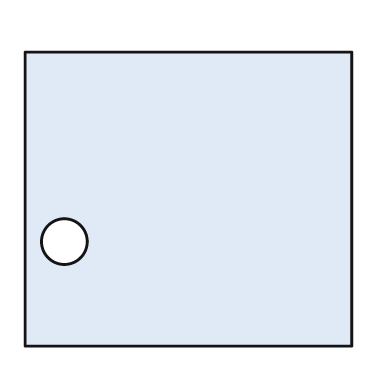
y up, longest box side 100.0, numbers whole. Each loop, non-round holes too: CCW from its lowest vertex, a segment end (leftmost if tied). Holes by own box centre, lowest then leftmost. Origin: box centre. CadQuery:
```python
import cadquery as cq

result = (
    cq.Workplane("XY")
    .moveTo(-50.0, -45.0)
    .lineTo(50.0, -45.0)
    .lineTo(50.0, 45.0)
    .lineTo(-50.0, 45.0)
    .close()
    .moveTo(-38.0, -13.0)
    .circle(7.0)
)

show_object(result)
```